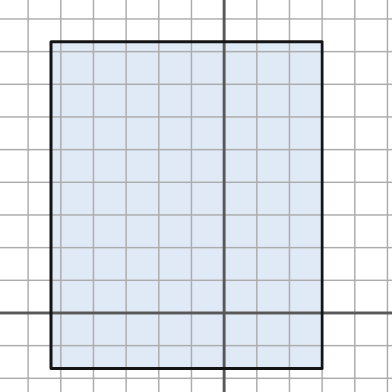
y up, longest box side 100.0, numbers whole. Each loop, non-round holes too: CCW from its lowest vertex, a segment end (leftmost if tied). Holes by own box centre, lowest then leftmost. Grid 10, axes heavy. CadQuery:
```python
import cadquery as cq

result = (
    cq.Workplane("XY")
    .moveTo(-53.0, -17.0)
    .lineTo(30.0, -17.0)
    .lineTo(30.0, 83.0)
    .lineTo(-53.0, 83.0)
    .close()
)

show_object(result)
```